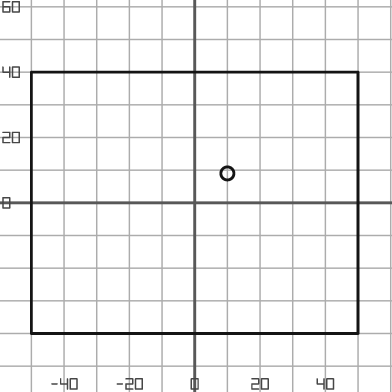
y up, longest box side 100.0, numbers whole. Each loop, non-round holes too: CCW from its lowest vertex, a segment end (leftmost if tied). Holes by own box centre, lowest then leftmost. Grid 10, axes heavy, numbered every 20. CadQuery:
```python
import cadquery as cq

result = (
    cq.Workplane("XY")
    .moveTo(-50.0, -40.0)
    .lineTo(50.0, -40.0)
    .lineTo(50.0, 40.0)
    .lineTo(-50.0, 40.0)
    .close()
    .moveTo(10.0, 9.0)
    .circle(2.0)
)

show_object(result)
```